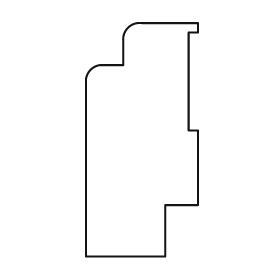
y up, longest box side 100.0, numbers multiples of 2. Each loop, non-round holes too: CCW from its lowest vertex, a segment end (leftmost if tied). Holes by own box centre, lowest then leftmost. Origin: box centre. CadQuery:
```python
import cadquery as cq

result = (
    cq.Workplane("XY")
    .moveTo(-24.0, -50.0)
    .lineTo(10.0, -50.0)
    .lineTo(10.0, -28.0)
    .lineTo(24.0, -28.0)
    .lineTo(24.0, 4.0)
    .lineTo(20.0, 4.0)
    .lineTo(20.0, 46.0)
    .lineTo(24.0, 46.0)
    .lineTo(24.0, 50.0)
    .lineTo(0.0, 50.0)
    .threePointArc((-6.0, 48.0), (-8.0, 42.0))
    .lineTo(-8.0, 32.0)
    .lineTo(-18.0, 32.0)
    .threePointArc((-22.0, 30.0), (-24.0, 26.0))
    .close()
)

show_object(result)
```